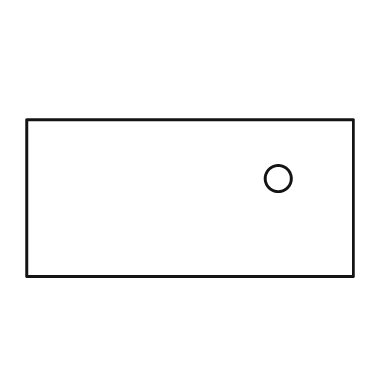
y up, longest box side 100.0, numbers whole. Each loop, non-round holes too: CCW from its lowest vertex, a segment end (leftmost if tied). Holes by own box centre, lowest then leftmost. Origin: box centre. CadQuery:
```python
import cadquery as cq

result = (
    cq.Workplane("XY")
    .moveTo(-50.0, -24.0)
    .lineTo(50.0, -24.0)
    .lineTo(50.0, 24.0)
    .lineTo(-50.0, 24.0)
    .close()
    .moveTo(27.0, 6.0)
    .circle(4.0)
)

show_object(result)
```